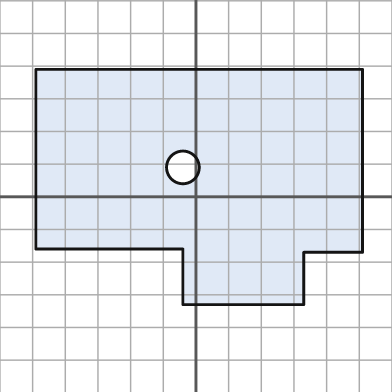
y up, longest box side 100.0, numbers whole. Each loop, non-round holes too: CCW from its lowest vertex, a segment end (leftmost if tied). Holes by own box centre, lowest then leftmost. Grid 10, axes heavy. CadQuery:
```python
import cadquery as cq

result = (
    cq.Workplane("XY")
    .moveTo(-4.0, -33.0)
    .lineTo(33.0, -33.0)
    .lineTo(33.0, -17.0)
    .lineTo(51.0, -17.0)
    .lineTo(51.0, 39.0)
    .lineTo(-49.0, 39.0)
    .lineTo(-49.0, -16.0)
    .lineTo(-4.0, -16.0)
    .close()
    .moveTo(-4.0, 9.0)
    .circle(5.0)
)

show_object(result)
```